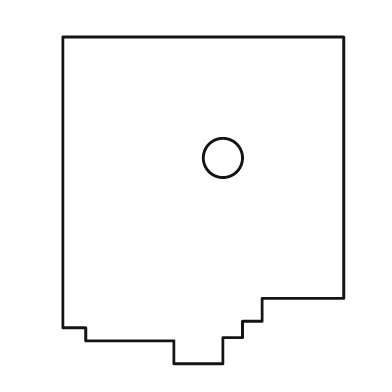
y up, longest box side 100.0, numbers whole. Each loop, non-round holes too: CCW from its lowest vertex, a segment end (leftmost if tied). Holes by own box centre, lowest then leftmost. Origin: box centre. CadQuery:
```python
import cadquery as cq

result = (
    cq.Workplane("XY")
    .moveTo(-9.0, -50.0)
    .lineTo(6.0, -50.0)
    .lineTo(6.0, -42.0)
    .lineTo(12.0, -42.0)
    .lineTo(12.0, -37.0)
    .lineTo(18.0, -37.0)
    .lineTo(18.0, -30.0)
    .lineTo(43.0, -30.0)
    .lineTo(43.0, 50.0)
    .lineTo(-43.0, 50.0)
    .lineTo(-43.0, -39.0)
    .lineTo(-36.0, -39.0)
    .lineTo(-36.0, -43.0)
    .lineTo(-9.0, -43.0)
    .close()
    .moveTo(6.0, 13.0)
    .circle(6.0)
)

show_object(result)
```